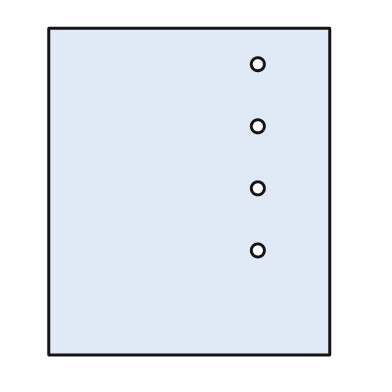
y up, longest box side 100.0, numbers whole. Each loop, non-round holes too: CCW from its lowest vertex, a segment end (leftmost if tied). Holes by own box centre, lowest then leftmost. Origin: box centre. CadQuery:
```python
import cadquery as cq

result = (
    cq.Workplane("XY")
    .moveTo(-43.0, -50.0)
    .lineTo(43.0, -50.0)
    .lineTo(43.0, 50.0)
    .lineTo(-43.0, 50.0)
    .close()
    .moveTo(21.0, -18.0)
    .circle(2.0)
    .moveTo(21.0, 1.0)
    .circle(2.0)
    .moveTo(21.0, 20.0)
    .circle(2.0)
    .moveTo(21.0, 39.0)
    .circle(2.0)
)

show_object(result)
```